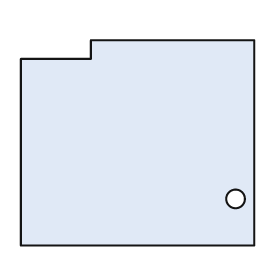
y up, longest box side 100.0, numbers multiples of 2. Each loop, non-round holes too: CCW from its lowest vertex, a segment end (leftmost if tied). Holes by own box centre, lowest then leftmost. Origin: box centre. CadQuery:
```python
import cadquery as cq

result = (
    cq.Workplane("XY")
    .moveTo(-50.0, -44.0)
    .lineTo(50.0, -44.0)
    .lineTo(50.0, 44.0)
    .lineTo(-20.0, 44.0)
    .lineTo(-20.0, 36.0)
    .lineTo(-50.0, 36.0)
    .close()
    .moveTo(42.0, -24.0)
    .circle(4.0)
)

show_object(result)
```